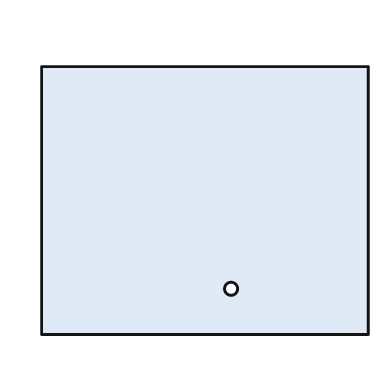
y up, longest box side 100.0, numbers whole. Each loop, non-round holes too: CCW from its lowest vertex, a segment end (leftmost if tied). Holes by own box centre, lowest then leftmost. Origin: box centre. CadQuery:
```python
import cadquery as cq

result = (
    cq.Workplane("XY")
    .moveTo(-50.0, -41.0)
    .lineTo(50.0, -41.0)
    .lineTo(50.0, 41.0)
    .lineTo(-50.0, 41.0)
    .close()
    .moveTo(8.0, -27.0)
    .circle(2.0)
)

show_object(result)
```